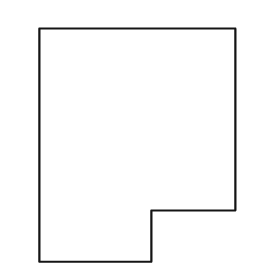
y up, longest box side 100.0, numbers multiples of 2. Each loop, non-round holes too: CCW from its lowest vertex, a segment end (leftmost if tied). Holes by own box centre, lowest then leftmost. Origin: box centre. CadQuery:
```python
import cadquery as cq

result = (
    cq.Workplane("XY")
    .moveTo(-42.0, -50.0)
    .lineTo(6.0, -50.0)
    .lineTo(6.0, -28.0)
    .lineTo(42.0, -28.0)
    .lineTo(42.0, 50.0)
    .lineTo(-42.0, 50.0)
    .close()
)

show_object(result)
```